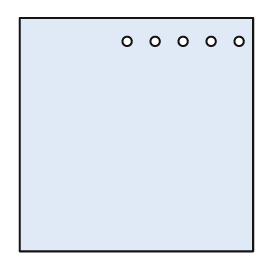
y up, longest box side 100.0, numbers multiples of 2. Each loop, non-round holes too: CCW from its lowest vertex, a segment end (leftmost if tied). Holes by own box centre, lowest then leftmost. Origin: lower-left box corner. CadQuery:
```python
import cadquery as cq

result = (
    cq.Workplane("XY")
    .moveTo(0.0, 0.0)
    .lineTo(100.0, 0.0)
    .lineTo(100.0, 100.0)
    .lineTo(0.0, 100.0)
    .close()
    .moveTo(46.0, 90.0)
    .circle(2.0)
    .moveTo(58.0, 90.0)
    .circle(2.0)
    .moveTo(70.0, 90.0)
    .circle(2.0)
    .moveTo(82.0, 90.0)
    .circle(2.0)
    .moveTo(94.0, 90.0)
    .circle(2.0)
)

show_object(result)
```